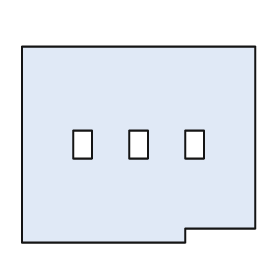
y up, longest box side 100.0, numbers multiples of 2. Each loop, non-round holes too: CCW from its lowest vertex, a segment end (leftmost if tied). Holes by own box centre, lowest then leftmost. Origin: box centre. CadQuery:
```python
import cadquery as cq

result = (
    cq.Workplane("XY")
    .moveTo(-50.0, -42.0)
    .lineTo(20.0, -42.0)
    .lineTo(20.0, -36.0)
    .lineTo(50.0, -36.0)
    .lineTo(50.0, 42.0)
    .lineTo(-50.0, 42.0)
    .close()
    .moveTo(-28.0, -6.0)
    .lineTo(-20.0, -6.0)
    .lineTo(-20.0, 6.0)
    .lineTo(-28.0, 6.0)
    .close()
    .moveTo(-4.0, -6.0)
    .lineTo(4.0, -6.0)
    .lineTo(4.0, 6.0)
    .lineTo(-4.0, 6.0)
    .close()
    .moveTo(20.0, -6.0)
    .lineTo(28.0, -6.0)
    .lineTo(28.0, 6.0)
    .lineTo(20.0, 6.0)
    .close()
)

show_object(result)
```